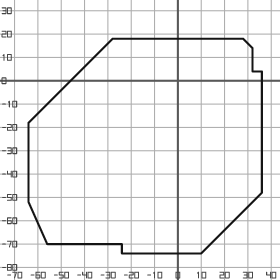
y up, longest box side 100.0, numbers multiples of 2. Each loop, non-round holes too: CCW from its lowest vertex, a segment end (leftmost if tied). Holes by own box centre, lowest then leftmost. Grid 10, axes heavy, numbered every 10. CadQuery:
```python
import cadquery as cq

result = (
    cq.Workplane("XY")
    .moveTo(-24.0, -74.0)
    .lineTo(10.0, -74.0)
    .lineTo(36.0, -48.0)
    .lineTo(36.0, 4.0)
    .lineTo(32.0, 4.0)
    .lineTo(32.0, 14.0)
    .lineTo(28.0, 18.0)
    .lineTo(-28.0, 18.0)
    .lineTo(-64.0, -18.0)
    .lineTo(-64.0, -52.0)
    .lineTo(-56.0, -70.0)
    .lineTo(-24.0, -70.0)
    .close()
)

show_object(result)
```